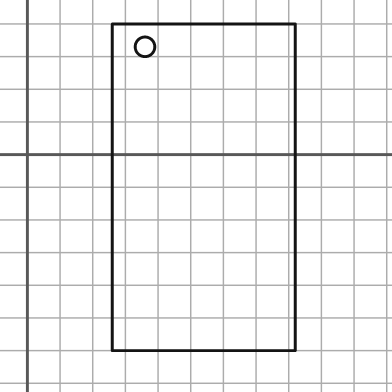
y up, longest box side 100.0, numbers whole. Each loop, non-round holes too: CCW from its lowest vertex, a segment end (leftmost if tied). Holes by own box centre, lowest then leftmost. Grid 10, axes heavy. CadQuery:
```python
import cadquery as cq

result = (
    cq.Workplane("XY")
    .moveTo(26.0, -60.0)
    .lineTo(82.0, -60.0)
    .lineTo(82.0, 40.0)
    .lineTo(26.0, 40.0)
    .close()
    .moveTo(36.0, 33.0)
    .circle(3.0)
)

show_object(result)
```